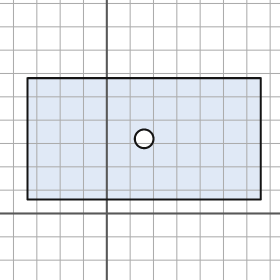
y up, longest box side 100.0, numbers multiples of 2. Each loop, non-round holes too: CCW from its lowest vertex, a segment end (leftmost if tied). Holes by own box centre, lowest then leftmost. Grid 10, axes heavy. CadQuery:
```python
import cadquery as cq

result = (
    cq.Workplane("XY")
    .moveTo(-34.0, 6.0)
    .lineTo(66.0, 6.0)
    .lineTo(66.0, 58.0)
    .lineTo(-34.0, 58.0)
    .close()
    .moveTo(16.0, 32.0)
    .circle(4.0)
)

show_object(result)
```